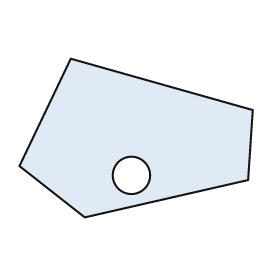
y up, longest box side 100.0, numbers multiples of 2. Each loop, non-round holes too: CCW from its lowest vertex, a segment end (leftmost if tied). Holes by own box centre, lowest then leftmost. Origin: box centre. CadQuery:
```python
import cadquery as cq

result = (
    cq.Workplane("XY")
    .moveTo(-22.0, -34.0)
    .lineTo(48.0, -18.0)
    .lineTo(50.0, 12.0)
    .lineTo(-28.0, 34.0)
    .lineTo(-50.0, -12.0)
    .close()
    .moveTo(-2.0, -16.0)
    .circle(8.0)
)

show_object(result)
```